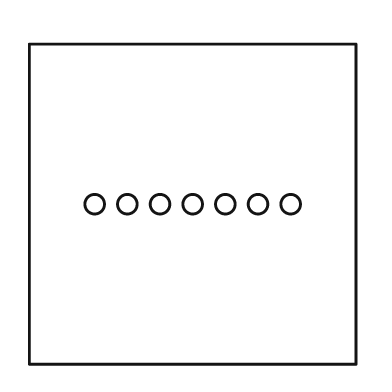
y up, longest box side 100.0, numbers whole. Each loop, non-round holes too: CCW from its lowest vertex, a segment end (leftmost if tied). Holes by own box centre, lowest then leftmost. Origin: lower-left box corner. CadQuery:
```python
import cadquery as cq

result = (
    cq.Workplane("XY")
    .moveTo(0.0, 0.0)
    .lineTo(100.0, 0.0)
    .lineTo(100.0, 98.0)
    .lineTo(0.0, 98.0)
    .close()
    .moveTo(20.0, 49.0)
    .circle(3.0)
    .moveTo(30.0, 49.0)
    .circle(3.0)
    .moveTo(40.0, 49.0)
    .circle(3.0)
    .moveTo(50.0, 49.0)
    .circle(3.0)
    .moveTo(60.0, 49.0)
    .circle(3.0)
    .moveTo(70.0, 49.0)
    .circle(3.0)
    .moveTo(80.0, 49.0)
    .circle(3.0)
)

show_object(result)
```